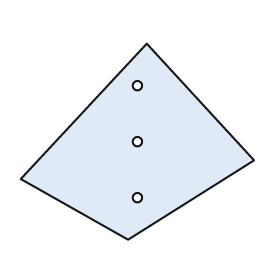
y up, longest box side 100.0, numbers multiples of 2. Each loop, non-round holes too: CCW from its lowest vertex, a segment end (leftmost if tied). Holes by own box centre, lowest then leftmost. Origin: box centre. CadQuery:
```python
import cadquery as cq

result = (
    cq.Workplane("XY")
    .moveTo(-4.0, -42.0)
    .lineTo(50.0, -8.0)
    .lineTo(4.0, 42.0)
    .lineTo(-50.0, -16.0)
    .close()
    .moveTo(0.0, -24.0)
    .circle(2.0)
    .moveTo(0.0, 0.0)
    .circle(2.0)
    .moveTo(0.0, 24.0)
    .circle(2.0)
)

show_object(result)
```